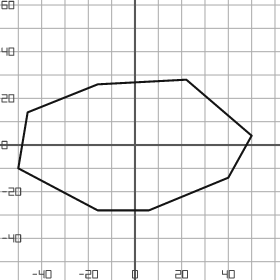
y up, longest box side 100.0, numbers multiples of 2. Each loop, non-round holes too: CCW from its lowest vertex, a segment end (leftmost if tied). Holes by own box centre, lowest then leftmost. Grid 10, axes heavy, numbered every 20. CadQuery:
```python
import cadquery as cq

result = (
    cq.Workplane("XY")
    .moveTo(-16.0, -28.0)
    .lineTo(6.0, -28.0)
    .lineTo(40.0, -14.0)
    .lineTo(50.0, 4.0)
    .lineTo(22.0, 28.0)
    .lineTo(-16.0, 26.0)
    .lineTo(-46.0, 14.0)
    .lineTo(-50.0, -10.0)
    .close()
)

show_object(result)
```